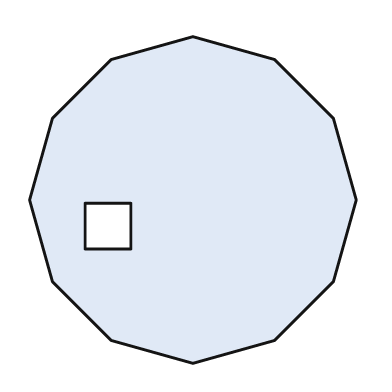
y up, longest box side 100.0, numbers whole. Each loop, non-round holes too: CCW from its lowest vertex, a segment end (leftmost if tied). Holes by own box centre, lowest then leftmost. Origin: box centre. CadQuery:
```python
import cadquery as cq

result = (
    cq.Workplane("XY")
    .moveTo(0.0, -50.0)
    .lineTo(25.0, -43.0)
    .lineTo(43.0, -25.0)
    .lineTo(50.0, 0.0)
    .lineTo(43.0, 25.0)
    .lineTo(25.0, 43.0)
    .lineTo(0.0, 50.0)
    .lineTo(-25.0, 43.0)
    .lineTo(-43.0, 25.0)
    .lineTo(-50.0, 0.0)
    .lineTo(-43.0, -25.0)
    .lineTo(-25.0, -43.0)
    .close()
    .moveTo(-33.0, -15.0)
    .lineTo(-19.0, -15.0)
    .lineTo(-19.0, -1.0)
    .lineTo(-33.0, -1.0)
    .close()
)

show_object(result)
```